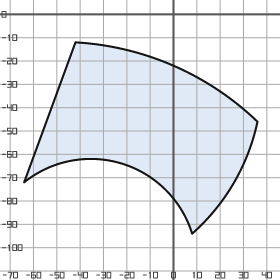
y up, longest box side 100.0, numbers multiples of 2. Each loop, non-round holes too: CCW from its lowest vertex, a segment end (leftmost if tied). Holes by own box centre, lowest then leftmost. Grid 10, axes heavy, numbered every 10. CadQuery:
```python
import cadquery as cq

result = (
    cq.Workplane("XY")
    .moveTo(8.0, -94.0)
    .threePointArc((26.0, -72.0), (36.0, -46.0))
    .threePointArc((0.0, -22.0), (-42.0, -12.0))
    .lineTo(-64.0, -72.0)
    .threePointArc((-22.0, -64.0), (8.0, -94.0))
    .close()
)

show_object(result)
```